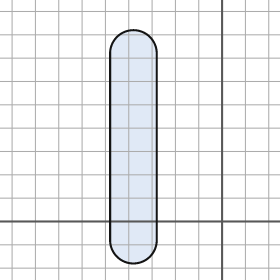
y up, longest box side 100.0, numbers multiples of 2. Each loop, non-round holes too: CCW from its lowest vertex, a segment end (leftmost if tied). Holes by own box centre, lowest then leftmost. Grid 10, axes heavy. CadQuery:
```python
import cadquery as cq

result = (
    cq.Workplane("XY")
    .moveTo(-48.0, -8.0)
    .threePointArc((-38.0, -18.0), (-28.0, -8.0))
    .lineTo(-28.0, 72.0)
    .threePointArc((-38.0, 82.0), (-48.0, 72.0))
    .close()
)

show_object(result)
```